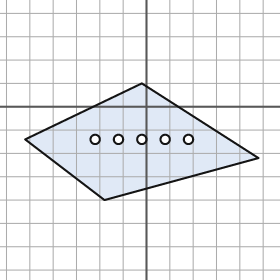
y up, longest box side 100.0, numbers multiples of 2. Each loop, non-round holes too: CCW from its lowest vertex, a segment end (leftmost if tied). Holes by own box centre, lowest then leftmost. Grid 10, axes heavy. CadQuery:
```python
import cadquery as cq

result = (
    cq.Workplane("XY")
    .moveTo(-18.0, -40.0)
    .lineTo(48.0, -22.0)
    .lineTo(-2.0, 10.0)
    .lineTo(-52.0, -14.0)
    .close()
    .moveTo(-22.0, -14.0)
    .circle(2.0)
    .moveTo(-12.0, -14.0)
    .circle(2.0)
    .moveTo(-2.0, -14.0)
    .circle(2.0)
    .moveTo(8.0, -14.0)
    .circle(2.0)
    .moveTo(18.0, -14.0)
    .circle(2.0)
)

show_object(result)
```